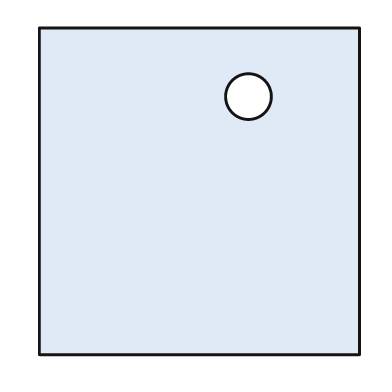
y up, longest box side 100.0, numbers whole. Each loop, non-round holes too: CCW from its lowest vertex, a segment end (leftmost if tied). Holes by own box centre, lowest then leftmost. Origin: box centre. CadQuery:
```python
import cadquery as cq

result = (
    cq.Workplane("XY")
    .moveTo(-49.0, -50.0)
    .lineTo(49.0, -50.0)
    .lineTo(49.0, 50.0)
    .lineTo(-49.0, 50.0)
    .close()
    .moveTo(15.0, 29.0)
    .circle(7.0)
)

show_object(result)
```